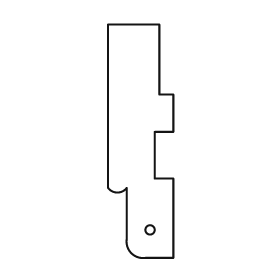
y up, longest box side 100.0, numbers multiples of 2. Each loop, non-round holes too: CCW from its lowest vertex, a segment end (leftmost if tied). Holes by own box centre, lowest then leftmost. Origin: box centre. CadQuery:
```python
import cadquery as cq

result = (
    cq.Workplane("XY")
    .moveTo(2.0, -50.0)
    .lineTo(14.0, -50.0)
    .lineTo(14.0, -16.0)
    .lineTo(6.0, -16.0)
    .lineTo(6.0, 4.0)
    .lineTo(14.0, 4.0)
    .lineTo(14.0, 20.0)
    .lineTo(8.0, 20.0)
    .lineTo(8.0, 50.0)
    .lineTo(-14.0, 50.0)
    .lineTo(-14.0, -20.0)
    .threePointArc((-10.0, -22.0), (-6.0, -20.0))
    .lineTo(-6.0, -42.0)
    .threePointArc((-4.0, -48.0), (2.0, -50.0))
    .close()
    .moveTo(4.0, -38.0)
    .circle(2.0)
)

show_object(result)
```